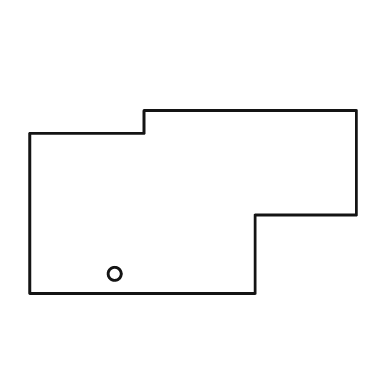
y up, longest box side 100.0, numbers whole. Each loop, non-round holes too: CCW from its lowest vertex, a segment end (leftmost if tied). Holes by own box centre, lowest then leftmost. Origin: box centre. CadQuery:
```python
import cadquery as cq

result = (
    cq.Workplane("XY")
    .moveTo(-50.0, -28.0)
    .lineTo(19.0, -28.0)
    .lineTo(19.0, -4.0)
    .lineTo(50.0, -4.0)
    .lineTo(50.0, 28.0)
    .lineTo(-15.0, 28.0)
    .lineTo(-15.0, 21.0)
    .lineTo(-50.0, 21.0)
    .close()
    .moveTo(-24.0, -22.0)
    .circle(2.0)
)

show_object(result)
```